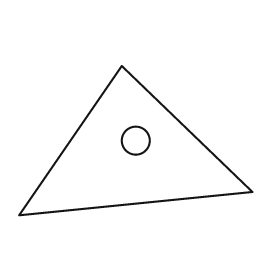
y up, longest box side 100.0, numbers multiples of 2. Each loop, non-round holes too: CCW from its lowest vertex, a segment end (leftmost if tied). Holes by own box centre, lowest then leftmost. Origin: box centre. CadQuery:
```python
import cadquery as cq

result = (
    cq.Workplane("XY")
    .moveTo(-50.0, -32.0)
    .lineTo(50.0, -22.0)
    .lineTo(-6.0, 32.0)
    .close()
    .moveTo(0.0, 0.0)
    .circle(6.0)
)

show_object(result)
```